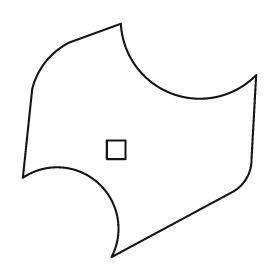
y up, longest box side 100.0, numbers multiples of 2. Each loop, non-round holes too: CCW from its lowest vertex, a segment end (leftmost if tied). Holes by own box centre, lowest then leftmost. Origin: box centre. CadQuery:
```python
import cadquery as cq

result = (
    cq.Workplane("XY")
    .moveTo(-12.0, -50.0)
    .lineTo(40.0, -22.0)
    .threePointArc((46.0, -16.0), (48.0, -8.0))
    .lineTo(50.0, 28.0)
    .threePointArc((14.0, 20.0), (-8.0, 50.0))
    .lineTo(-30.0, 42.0)
    .threePointArc((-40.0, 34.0), (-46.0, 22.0))
    .lineTo(-50.0, -16.0)
    .threePointArc((-18.0, -18.0), (-12.0, -50.0))
    .close()
    .moveTo(-14.0, -8.0)
    .lineTo(-6.0, -8.0)
    .lineTo(-6.0, 0.0)
    .lineTo(-14.0, 0.0)
    .close()
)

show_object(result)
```